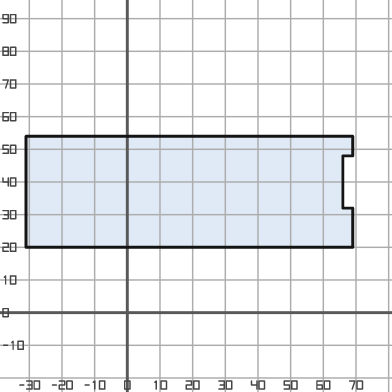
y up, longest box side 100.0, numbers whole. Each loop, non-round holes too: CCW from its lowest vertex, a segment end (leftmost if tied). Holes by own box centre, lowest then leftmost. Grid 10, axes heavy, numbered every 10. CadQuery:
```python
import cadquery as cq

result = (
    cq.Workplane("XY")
    .moveTo(-31.0, 20.0)
    .lineTo(69.0, 20.0)
    .lineTo(69.0, 32.0)
    .lineTo(66.0, 32.0)
    .lineTo(66.0, 48.0)
    .lineTo(69.0, 48.0)
    .lineTo(69.0, 54.0)
    .lineTo(-31.0, 54.0)
    .close()
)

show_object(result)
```